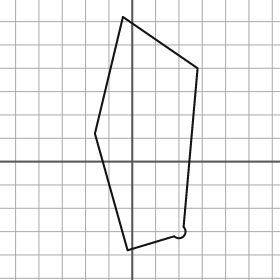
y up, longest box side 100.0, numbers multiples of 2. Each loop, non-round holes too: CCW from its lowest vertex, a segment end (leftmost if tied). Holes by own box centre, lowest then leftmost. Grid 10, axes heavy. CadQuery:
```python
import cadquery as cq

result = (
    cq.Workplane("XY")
    .moveTo(-2.0, -38.0)
    .lineTo(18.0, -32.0)
    .threePointArc((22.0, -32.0), (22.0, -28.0))
    .lineTo(28.0, 40.0)
    .lineTo(-4.0, 62.0)
    .lineTo(-16.0, 12.0)
    .close()
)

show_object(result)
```